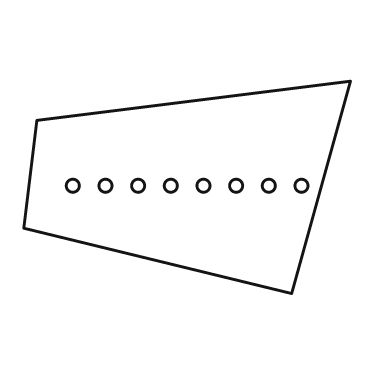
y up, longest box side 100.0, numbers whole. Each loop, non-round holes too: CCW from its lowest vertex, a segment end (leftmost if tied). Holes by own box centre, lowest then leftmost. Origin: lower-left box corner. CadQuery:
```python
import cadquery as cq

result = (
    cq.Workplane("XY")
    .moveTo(82.0, 0.0)
    .lineTo(100.0, 65.0)
    .lineTo(4.0, 53.0)
    .lineTo(0.0, 20.0)
    .close()
    .moveTo(15.0, 33.0)
    .circle(2.0)
    .moveTo(25.0, 33.0)
    .circle(2.0)
    .moveTo(35.0, 33.0)
    .circle(2.0)
    .moveTo(45.0, 33.0)
    .circle(2.0)
    .moveTo(55.0, 33.0)
    .circle(2.0)
    .moveTo(65.0, 33.0)
    .circle(2.0)
    .moveTo(75.0, 33.0)
    .circle(2.0)
    .moveTo(85.0, 33.0)
    .circle(2.0)
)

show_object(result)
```